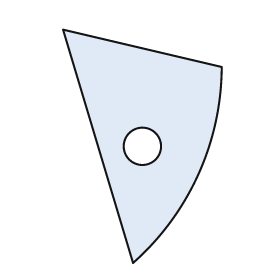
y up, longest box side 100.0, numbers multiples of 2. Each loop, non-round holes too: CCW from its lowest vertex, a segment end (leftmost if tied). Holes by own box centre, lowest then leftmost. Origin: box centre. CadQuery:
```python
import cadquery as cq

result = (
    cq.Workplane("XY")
    .moveTo(-4.0, -50.0)
    .threePointArc((24.0, -12.0), (34.0, 34.0))
    .lineTo(-34.0, 50.0)
    .close()
    .moveTo(0.0, 0.0)
    .circle(8.0)
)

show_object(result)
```